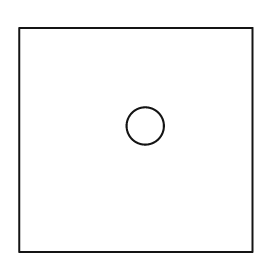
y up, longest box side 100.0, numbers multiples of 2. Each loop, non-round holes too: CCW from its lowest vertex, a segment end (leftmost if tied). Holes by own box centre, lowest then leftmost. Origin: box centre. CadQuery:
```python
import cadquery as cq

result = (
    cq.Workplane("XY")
    .moveTo(-50.0, -48.0)
    .lineTo(50.0, -48.0)
    .lineTo(50.0, 48.0)
    .lineTo(-50.0, 48.0)
    .close()
    .moveTo(4.0, 6.0)
    .circle(8.0)
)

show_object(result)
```